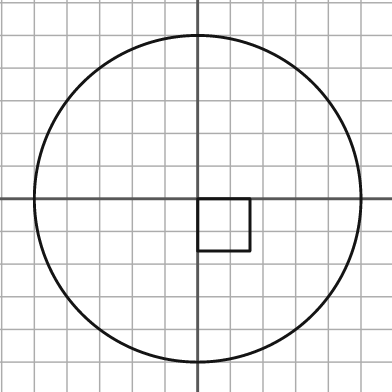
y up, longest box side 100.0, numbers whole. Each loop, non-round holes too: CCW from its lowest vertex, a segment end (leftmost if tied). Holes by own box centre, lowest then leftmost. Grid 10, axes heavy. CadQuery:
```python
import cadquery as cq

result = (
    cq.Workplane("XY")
    .moveTo(0.0, 0.0)
    .circle(50.0)
    .moveTo(0.0, -16.0)
    .lineTo(16.0, -16.0)
    .lineTo(16.0, 0.0)
    .lineTo(0.0, 0.0)
    .close()
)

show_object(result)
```